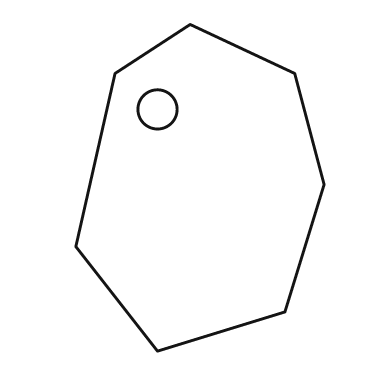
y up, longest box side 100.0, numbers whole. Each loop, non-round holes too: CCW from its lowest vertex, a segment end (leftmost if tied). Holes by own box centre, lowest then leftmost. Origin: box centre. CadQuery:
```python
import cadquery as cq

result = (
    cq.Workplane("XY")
    .moveTo(-13.0, -50.0)
    .lineTo(26.0, -38.0)
    .lineTo(38.0, 1.0)
    .lineTo(29.0, 35.0)
    .lineTo(-3.0, 50.0)
    .lineTo(-26.0, 35.0)
    .lineTo(-38.0, -18.0)
    .close()
    .moveTo(-13.0, 24.0)
    .circle(6.0)
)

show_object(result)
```